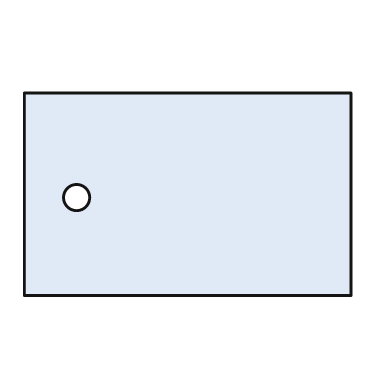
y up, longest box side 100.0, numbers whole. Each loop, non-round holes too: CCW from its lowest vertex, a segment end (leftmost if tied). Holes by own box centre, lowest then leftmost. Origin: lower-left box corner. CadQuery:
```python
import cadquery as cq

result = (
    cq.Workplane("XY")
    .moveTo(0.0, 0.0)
    .lineTo(100.0, 0.0)
    .lineTo(100.0, 62.0)
    .lineTo(0.0, 62.0)
    .close()
    .moveTo(16.0, 30.0)
    .circle(4.0)
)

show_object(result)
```